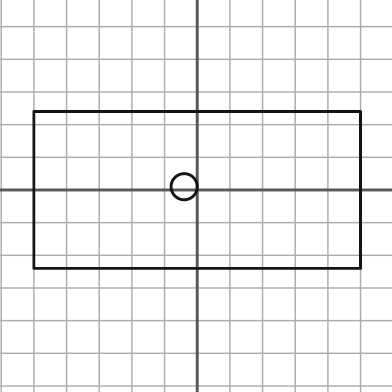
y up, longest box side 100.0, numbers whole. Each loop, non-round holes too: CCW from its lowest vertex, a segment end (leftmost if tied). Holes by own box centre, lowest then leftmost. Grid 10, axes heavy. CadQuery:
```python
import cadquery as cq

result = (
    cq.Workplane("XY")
    .moveTo(-50.0, -24.0)
    .lineTo(50.0, -24.0)
    .lineTo(50.0, 24.0)
    .lineTo(-50.0, 24.0)
    .close()
    .moveTo(-4.0, 1.0)
    .circle(4.0)
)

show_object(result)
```